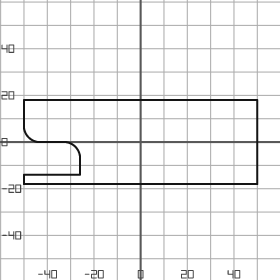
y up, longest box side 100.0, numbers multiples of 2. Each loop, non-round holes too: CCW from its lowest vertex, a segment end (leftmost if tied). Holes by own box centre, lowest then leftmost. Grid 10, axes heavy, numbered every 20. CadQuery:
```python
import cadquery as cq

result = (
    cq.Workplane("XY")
    .moveTo(-50.0, -18.0)
    .lineTo(50.0, -18.0)
    .lineTo(50.0, 18.0)
    .lineTo(-50.0, 18.0)
    .lineTo(-50.0, 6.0)
    .threePointArc((-48.0, 2.0), (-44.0, 0.0))
    .lineTo(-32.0, 0.0)
    .threePointArc((-28.0, -2.0), (-26.0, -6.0))
    .lineTo(-26.0, -14.0)
    .lineTo(-50.0, -14.0)
    .close()
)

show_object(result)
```